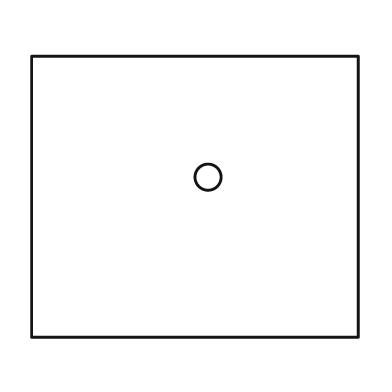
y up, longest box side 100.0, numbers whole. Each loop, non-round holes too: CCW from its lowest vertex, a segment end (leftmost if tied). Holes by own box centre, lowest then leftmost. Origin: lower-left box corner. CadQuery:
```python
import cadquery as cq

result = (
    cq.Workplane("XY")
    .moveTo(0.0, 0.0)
    .lineTo(100.0, 0.0)
    .lineTo(100.0, 86.0)
    .lineTo(0.0, 86.0)
    .close()
    .moveTo(54.0, 49.0)
    .circle(4.0)
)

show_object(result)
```